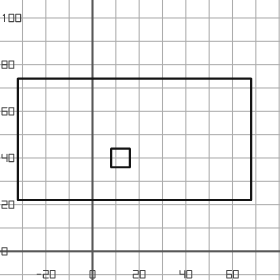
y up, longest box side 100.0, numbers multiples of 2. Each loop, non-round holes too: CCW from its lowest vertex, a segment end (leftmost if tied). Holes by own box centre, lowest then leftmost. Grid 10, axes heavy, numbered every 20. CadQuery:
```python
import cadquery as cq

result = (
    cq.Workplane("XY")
    .moveTo(-32.0, 22.0)
    .lineTo(68.0, 22.0)
    .lineTo(68.0, 74.0)
    .lineTo(-32.0, 74.0)
    .close()
    .moveTo(8.0, 36.0)
    .lineTo(16.0, 36.0)
    .lineTo(16.0, 44.0)
    .lineTo(8.0, 44.0)
    .close()
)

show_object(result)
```